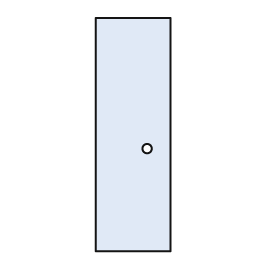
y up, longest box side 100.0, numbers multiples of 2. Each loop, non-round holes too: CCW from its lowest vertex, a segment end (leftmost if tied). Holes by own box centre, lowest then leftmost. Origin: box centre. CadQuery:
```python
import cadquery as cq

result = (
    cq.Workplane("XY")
    .moveTo(-16.0, -50.0)
    .lineTo(16.0, -50.0)
    .lineTo(16.0, 50.0)
    .lineTo(-16.0, 50.0)
    .close()
    .moveTo(6.0, -6.0)
    .circle(2.0)
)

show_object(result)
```